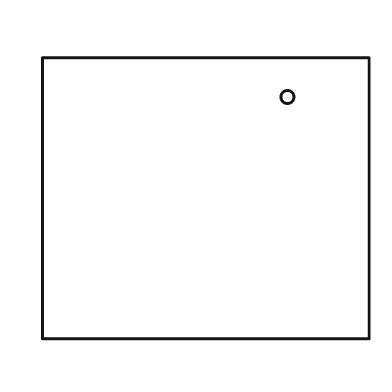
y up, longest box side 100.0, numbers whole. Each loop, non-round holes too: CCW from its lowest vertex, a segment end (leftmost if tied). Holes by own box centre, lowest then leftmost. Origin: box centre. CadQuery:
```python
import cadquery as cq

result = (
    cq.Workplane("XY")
    .moveTo(-50.0, -43.0)
    .lineTo(50.0, -43.0)
    .lineTo(50.0, 43.0)
    .lineTo(-50.0, 43.0)
    .close()
    .moveTo(25.0, 31.0)
    .circle(2.0)
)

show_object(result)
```